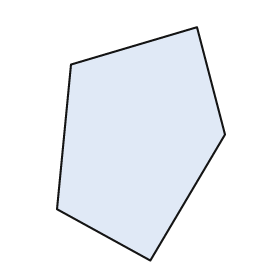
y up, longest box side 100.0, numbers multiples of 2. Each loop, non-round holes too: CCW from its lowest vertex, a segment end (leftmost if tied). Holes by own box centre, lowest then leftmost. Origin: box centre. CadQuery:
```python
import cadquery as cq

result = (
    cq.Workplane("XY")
    .moveTo(4.0, -50.0)
    .lineTo(36.0, 4.0)
    .lineTo(24.0, 50.0)
    .lineTo(-30.0, 34.0)
    .lineTo(-36.0, -28.0)
    .close()
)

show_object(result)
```